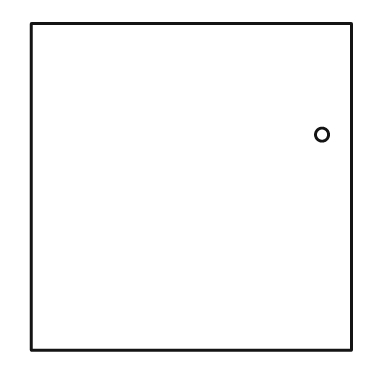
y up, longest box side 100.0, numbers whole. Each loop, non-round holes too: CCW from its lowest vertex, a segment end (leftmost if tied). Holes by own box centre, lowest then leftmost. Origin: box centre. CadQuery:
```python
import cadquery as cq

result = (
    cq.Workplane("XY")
    .moveTo(-49.0, -50.0)
    .lineTo(49.0, -50.0)
    .lineTo(49.0, 50.0)
    .lineTo(-49.0, 50.0)
    .close()
    .moveTo(40.0, 16.0)
    .circle(2.0)
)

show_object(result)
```